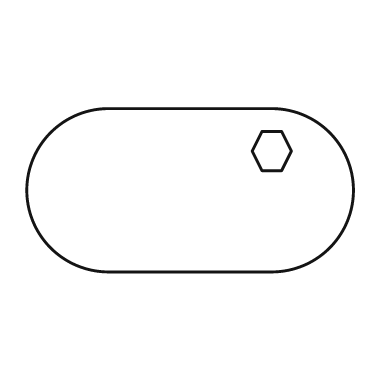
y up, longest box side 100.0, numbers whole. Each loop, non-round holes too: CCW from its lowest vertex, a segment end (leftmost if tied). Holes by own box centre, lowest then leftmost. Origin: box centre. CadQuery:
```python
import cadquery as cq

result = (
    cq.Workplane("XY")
    .moveTo(-25.0, -25.0)
    .lineTo(25.0, -25.0)
    .threePointArc((50.0, 0.0), (25.0, 25.0))
    .lineTo(-25.0, 25.0)
    .threePointArc((-50.0, 0.0), (-25.0, -25.0))
    .close()
    .moveTo(22.0, 6.0)
    .lineTo(28.0, 6.0)
    .lineTo(31.0, 12.0)
    .lineTo(28.0, 18.0)
    .lineTo(22.0, 18.0)
    .lineTo(19.0, 12.0)
    .close()
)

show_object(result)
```